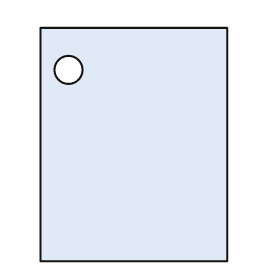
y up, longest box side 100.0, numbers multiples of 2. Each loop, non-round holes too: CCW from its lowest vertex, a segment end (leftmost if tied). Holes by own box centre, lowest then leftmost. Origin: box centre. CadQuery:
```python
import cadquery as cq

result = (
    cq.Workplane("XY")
    .moveTo(-40.0, -50.0)
    .lineTo(40.0, -50.0)
    .lineTo(40.0, 50.0)
    .lineTo(-40.0, 50.0)
    .close()
    .moveTo(-28.0, 32.0)
    .circle(6.0)
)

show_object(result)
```